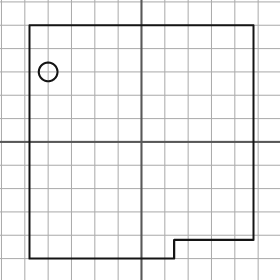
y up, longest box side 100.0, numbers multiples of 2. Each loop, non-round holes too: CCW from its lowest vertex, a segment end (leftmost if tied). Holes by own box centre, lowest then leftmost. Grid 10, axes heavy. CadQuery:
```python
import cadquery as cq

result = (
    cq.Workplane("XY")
    .moveTo(-48.0, -50.0)
    .lineTo(14.0, -50.0)
    .lineTo(14.0, -42.0)
    .lineTo(48.0, -42.0)
    .lineTo(48.0, 50.0)
    .lineTo(-48.0, 50.0)
    .close()
    .moveTo(-40.0, 30.0)
    .circle(4.0)
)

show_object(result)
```